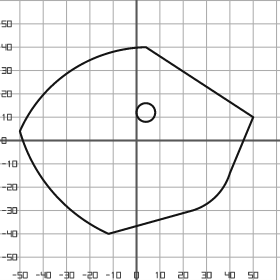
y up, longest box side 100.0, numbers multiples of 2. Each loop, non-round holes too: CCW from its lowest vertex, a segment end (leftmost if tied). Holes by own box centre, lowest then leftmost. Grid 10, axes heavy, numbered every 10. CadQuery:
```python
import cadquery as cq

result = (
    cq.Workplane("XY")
    .moveTo(-12.0, -40.0)
    .lineTo(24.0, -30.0)
    .threePointArc((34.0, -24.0), (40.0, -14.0))
    .lineTo(50.0, 10.0)
    .lineTo(4.0, 40.0)
    .threePointArc((-28.0, 30.0), (-50.0, 4.0))
    .threePointArc((-36.0, -22.0), (-12.0, -40.0))
    .close()
    .moveTo(4.0, 12.0)
    .circle(4.0)
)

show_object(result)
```